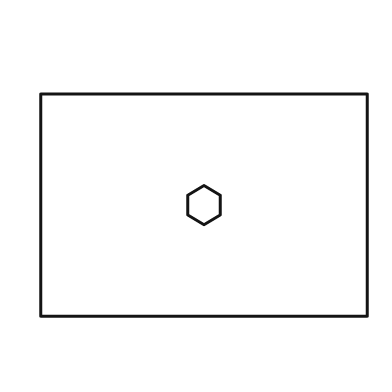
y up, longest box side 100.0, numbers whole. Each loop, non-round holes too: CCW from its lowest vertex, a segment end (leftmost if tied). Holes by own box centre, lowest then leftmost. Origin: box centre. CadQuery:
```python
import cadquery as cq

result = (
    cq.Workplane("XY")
    .moveTo(-50.0, -34.0)
    .lineTo(50.0, -34.0)
    .lineTo(50.0, 34.0)
    .lineTo(-50.0, 34.0)
    .close()
    .moveTo(0.0, -6.0)
    .lineTo(5.0, -3.0)
    .lineTo(5.0, 3.0)
    .lineTo(0.0, 6.0)
    .lineTo(-5.0, 3.0)
    .lineTo(-5.0, -3.0)
    .close()
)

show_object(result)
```